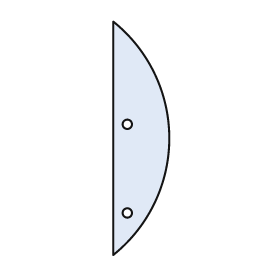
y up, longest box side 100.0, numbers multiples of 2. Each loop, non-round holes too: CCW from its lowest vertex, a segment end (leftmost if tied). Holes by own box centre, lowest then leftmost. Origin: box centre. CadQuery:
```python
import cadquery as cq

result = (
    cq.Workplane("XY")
    .moveTo(-12.0, -50.0)
    .threePointArc((12.0, 0.0), (-12.0, 50.0))
    .close()
    .moveTo(-6.0, -32.0)
    .circle(2.0)
    .moveTo(-6.0, 6.0)
    .circle(2.0)
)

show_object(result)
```